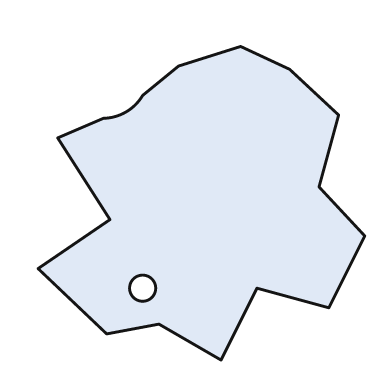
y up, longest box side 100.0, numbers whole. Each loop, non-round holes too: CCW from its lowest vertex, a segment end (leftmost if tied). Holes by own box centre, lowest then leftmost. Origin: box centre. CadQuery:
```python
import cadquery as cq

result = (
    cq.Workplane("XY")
    .moveTo(6.0, -48.0)
    .lineTo(17.0, -26.0)
    .lineTo(39.0, -32.0)
    .lineTo(50.0, -10.0)
    .lineTo(36.0, 5.0)
    .lineTo(42.0, 27.0)
    .lineTo(27.0, 41.0)
    .lineTo(12.0, 48.0)
    .lineTo(-7.0, 42.0)
    .lineTo(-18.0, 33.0)
    .threePointArc((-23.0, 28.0), (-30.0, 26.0))
    .lineTo(-44.0, 20.0)
    .lineTo(-28.0, -5.0)
    .lineTo(-50.0, -20.0)
    .lineTo(-29.0, -40.0)
    .lineTo(-13.0, -37.0)
    .close()
    .moveTo(-18.0, -26.0)
    .circle(4.0)
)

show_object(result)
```